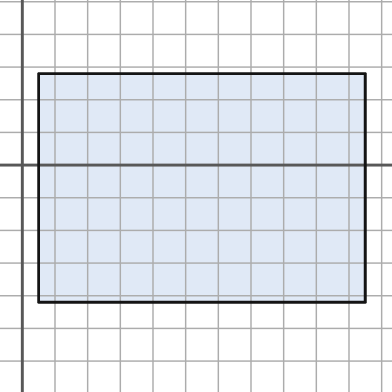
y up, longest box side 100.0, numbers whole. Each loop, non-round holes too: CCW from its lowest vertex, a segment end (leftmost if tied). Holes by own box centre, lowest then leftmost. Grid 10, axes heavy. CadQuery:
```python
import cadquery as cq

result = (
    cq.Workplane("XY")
    .moveTo(5.0, -42.0)
    .lineTo(105.0, -42.0)
    .lineTo(105.0, 28.0)
    .lineTo(5.0, 28.0)
    .close()
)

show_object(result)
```